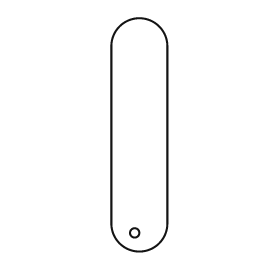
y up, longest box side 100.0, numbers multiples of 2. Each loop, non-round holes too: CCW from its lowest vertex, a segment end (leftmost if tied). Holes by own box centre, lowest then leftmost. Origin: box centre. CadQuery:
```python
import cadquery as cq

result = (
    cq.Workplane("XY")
    .moveTo(-12.0, -38.0)
    .threePointArc((0.0, -50.0), (12.0, -38.0))
    .lineTo(12.0, 38.0)
    .threePointArc((0.0, 50.0), (-12.0, 38.0))
    .close()
    .moveTo(-2.0, -42.0)
    .circle(2.0)
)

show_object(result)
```